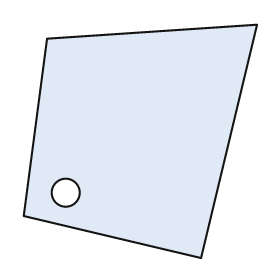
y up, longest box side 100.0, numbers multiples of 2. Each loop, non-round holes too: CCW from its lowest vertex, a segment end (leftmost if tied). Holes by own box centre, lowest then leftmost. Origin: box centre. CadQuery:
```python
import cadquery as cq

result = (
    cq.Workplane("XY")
    .moveTo(26.0, -50.0)
    .lineTo(50.0, 50.0)
    .lineTo(-40.0, 44.0)
    .lineTo(-50.0, -32.0)
    .close()
    .moveTo(-32.0, -22.0)
    .circle(6.0)
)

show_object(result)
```